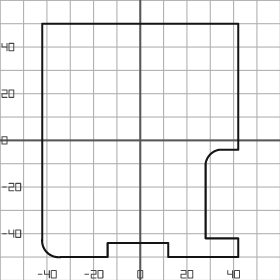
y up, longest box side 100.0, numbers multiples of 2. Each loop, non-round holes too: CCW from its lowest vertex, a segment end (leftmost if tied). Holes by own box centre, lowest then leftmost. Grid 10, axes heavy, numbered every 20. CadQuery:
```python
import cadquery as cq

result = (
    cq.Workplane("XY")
    .moveTo(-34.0, -50.0)
    .lineTo(-14.0, -50.0)
    .lineTo(-14.0, -44.0)
    .lineTo(12.0, -44.0)
    .lineTo(12.0, -50.0)
    .lineTo(42.0, -50.0)
    .lineTo(42.0, -42.0)
    .lineTo(28.0, -42.0)
    .lineTo(28.0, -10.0)
    .threePointArc((30.0, -6.0), (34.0, -4.0))
    .lineTo(42.0, -4.0)
    .lineTo(42.0, 50.0)
    .lineTo(-42.0, 50.0)
    .lineTo(-42.0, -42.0)
    .threePointArc((-40.0, -48.0), (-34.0, -50.0))
    .close()
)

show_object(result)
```